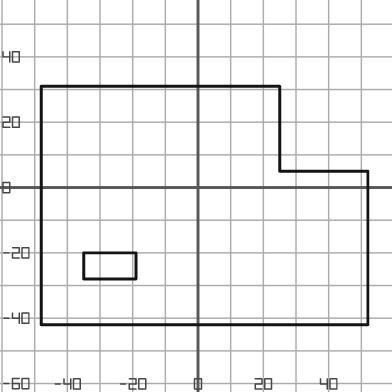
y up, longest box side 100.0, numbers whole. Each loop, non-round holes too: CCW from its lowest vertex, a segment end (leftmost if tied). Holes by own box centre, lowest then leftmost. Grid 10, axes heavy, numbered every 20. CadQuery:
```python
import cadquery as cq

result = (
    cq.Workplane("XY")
    .moveTo(-48.0, -42.0)
    .lineTo(52.0, -42.0)
    .lineTo(52.0, 5.0)
    .lineTo(25.0, 5.0)
    .lineTo(25.0, 31.0)
    .lineTo(-48.0, 31.0)
    .close()
    .moveTo(-35.0, -28.0)
    .lineTo(-19.0, -28.0)
    .lineTo(-19.0, -20.0)
    .lineTo(-35.0, -20.0)
    .close()
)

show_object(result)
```